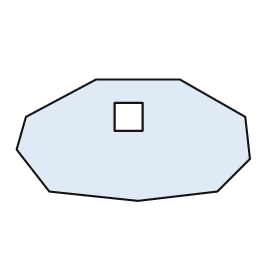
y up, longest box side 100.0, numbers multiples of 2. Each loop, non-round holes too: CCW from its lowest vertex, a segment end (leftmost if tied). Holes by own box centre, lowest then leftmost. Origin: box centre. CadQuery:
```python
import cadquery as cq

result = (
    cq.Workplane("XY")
    .moveTo(2.0, -26.0)
    .lineTo(36.0, -22.0)
    .lineTo(50.0, -8.0)
    .lineTo(48.0, 10.0)
    .lineTo(20.0, 26.0)
    .lineTo(-16.0, 26.0)
    .lineTo(-46.0, 10.0)
    .lineTo(-50.0, -4.0)
    .lineTo(-36.0, -22.0)
    .close()
    .moveTo(-8.0, 4.0)
    .lineTo(4.0, 4.0)
    .lineTo(4.0, 16.0)
    .lineTo(-8.0, 16.0)
    .close()
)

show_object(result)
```